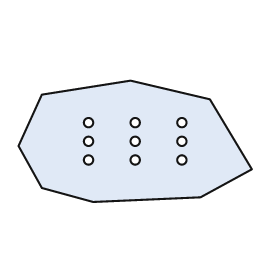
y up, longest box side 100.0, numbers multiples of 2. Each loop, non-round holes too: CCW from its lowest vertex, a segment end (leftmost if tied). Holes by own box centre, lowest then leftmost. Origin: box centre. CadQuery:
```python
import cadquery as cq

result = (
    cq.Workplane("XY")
    .moveTo(-18.0, -26.0)
    .lineTo(28.0, -24.0)
    .lineTo(50.0, -12.0)
    .lineTo(32.0, 18.0)
    .lineTo(-2.0, 26.0)
    .lineTo(-40.0, 20.0)
    .lineTo(-50.0, -2.0)
    .lineTo(-40.0, -20.0)
    .close()
    .moveTo(-20.0, -8.0)
    .circle(2.0)
    .moveTo(0.0, -8.0)
    .circle(2.0)
    .moveTo(20.0, -8.0)
    .circle(2.0)
    .moveTo(-20.0, 0.0)
    .circle(2.0)
    .moveTo(0.0, 0.0)
    .circle(2.0)
    .moveTo(20.0, 0.0)
    .circle(2.0)
    .moveTo(-20.0, 8.0)
    .circle(2.0)
    .moveTo(0.0, 8.0)
    .circle(2.0)
    .moveTo(20.0, 8.0)
    .circle(2.0)
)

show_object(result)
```